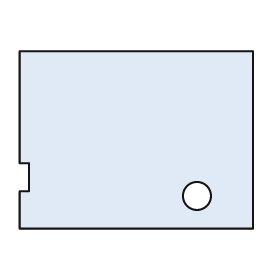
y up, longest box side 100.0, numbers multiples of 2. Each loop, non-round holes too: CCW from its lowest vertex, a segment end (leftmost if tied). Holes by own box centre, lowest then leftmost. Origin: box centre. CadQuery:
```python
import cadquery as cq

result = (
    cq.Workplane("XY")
    .moveTo(-50.0, -38.0)
    .lineTo(50.0, -38.0)
    .lineTo(50.0, 38.0)
    .lineTo(-50.0, 38.0)
    .lineTo(-50.0, -10.0)
    .lineTo(-46.0, -10.0)
    .lineTo(-46.0, -22.0)
    .lineTo(-50.0, -22.0)
    .close()
    .moveTo(26.0, -24.0)
    .circle(6.0)
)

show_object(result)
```